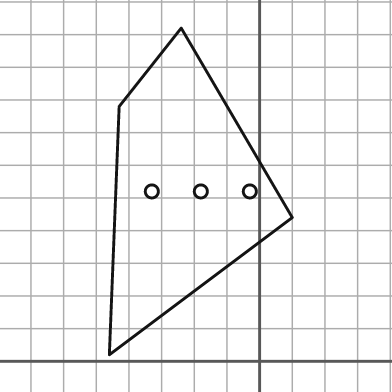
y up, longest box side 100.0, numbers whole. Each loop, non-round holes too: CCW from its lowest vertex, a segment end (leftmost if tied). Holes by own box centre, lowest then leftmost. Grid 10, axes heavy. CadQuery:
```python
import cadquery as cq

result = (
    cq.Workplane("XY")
    .moveTo(-46.0, 2.0)
    .lineTo(10.0, 44.0)
    .lineTo(-24.0, 102.0)
    .lineTo(-43.0, 78.0)
    .close()
    .moveTo(-33.0, 52.0)
    .circle(2.0)
    .moveTo(-18.0, 52.0)
    .circle(2.0)
    .moveTo(-3.0, 52.0)
    .circle(2.0)
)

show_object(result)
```